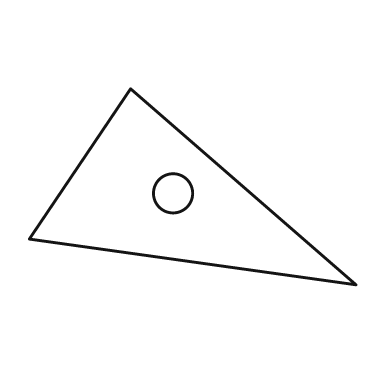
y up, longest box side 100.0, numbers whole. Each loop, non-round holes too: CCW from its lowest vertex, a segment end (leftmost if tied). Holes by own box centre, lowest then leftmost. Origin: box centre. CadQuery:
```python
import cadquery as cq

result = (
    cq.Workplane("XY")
    .moveTo(50.0, -30.0)
    .lineTo(-19.0, 30.0)
    .lineTo(-50.0, -16.0)
    .close()
    .moveTo(-6.0, -2.0)
    .circle(6.0)
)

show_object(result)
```